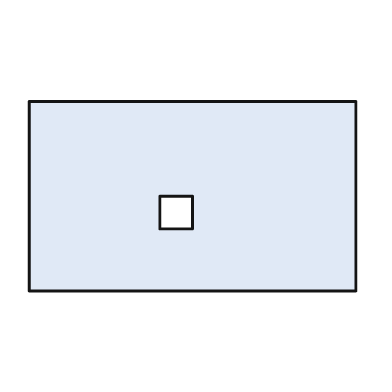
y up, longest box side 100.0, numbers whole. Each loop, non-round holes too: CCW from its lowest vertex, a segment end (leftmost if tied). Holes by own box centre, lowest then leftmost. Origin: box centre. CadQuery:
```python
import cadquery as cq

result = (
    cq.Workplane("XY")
    .moveTo(-50.0, -29.0)
    .lineTo(50.0, -29.0)
    .lineTo(50.0, 29.0)
    .lineTo(-50.0, 29.0)
    .close()
    .moveTo(-10.0, -10.0)
    .lineTo(0.0, -10.0)
    .lineTo(0.0, 0.0)
    .lineTo(-10.0, 0.0)
    .close()
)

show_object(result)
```